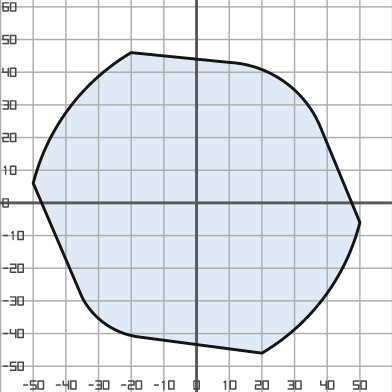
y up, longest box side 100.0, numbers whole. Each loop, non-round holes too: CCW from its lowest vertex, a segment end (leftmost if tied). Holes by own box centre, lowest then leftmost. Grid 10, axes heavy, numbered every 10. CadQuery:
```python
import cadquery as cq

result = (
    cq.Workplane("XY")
    .moveTo(20.0, -46.0)
    .threePointArc((39.0, -29.0), (50.0, -6.0))
    .lineTo(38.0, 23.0)
    .threePointArc((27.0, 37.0), (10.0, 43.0))
    .lineTo(-20.0, 46.0)
    .threePointArc((-39.0, 29.0), (-50.0, 6.0))
    .lineTo(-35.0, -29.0)
    .threePointArc((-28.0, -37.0), (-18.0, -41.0))
    .close()
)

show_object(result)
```